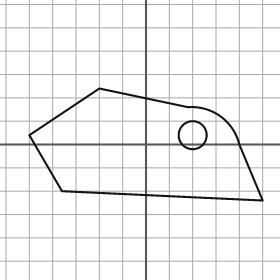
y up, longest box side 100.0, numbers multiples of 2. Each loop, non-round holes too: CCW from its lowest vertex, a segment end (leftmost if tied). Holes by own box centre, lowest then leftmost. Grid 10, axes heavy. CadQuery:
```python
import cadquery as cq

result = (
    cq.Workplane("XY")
    .moveTo(50.0, -24.0)
    .lineTo(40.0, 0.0)
    .threePointArc((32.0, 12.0), (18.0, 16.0))
    .lineTo(-20.0, 24.0)
    .lineTo(-50.0, 4.0)
    .lineTo(-36.0, -20.0)
    .close()
    .moveTo(20.0, 4.0)
    .circle(6.0)
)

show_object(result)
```